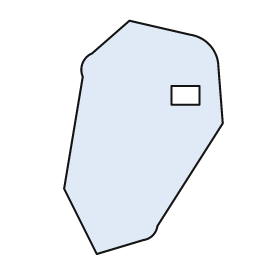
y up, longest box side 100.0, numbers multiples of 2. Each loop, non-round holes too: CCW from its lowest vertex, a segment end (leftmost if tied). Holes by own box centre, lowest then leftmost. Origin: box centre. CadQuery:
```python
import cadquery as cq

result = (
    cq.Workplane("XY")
    .moveTo(-20.0, -50.0)
    .lineTo(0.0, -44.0)
    .threePointArc((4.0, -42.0), (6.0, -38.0))
    .lineTo(34.0, 6.0)
    .lineTo(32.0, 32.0)
    .threePointArc((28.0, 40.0), (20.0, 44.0))
    .lineTo(-6.0, 50.0)
    .lineTo(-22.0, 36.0)
    .threePointArc((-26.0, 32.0), (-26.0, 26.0))
    .lineTo(-34.0, -22.0)
    .close()
    .moveTo(12.0, 14.0)
    .lineTo(24.0, 14.0)
    .lineTo(24.0, 22.0)
    .lineTo(12.0, 22.0)
    .close()
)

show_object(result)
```